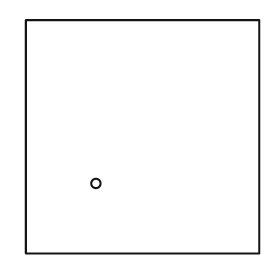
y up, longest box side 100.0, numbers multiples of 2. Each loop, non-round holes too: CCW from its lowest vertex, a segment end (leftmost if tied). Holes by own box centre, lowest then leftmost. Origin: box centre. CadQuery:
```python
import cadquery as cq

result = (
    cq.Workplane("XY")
    .moveTo(-50.0, -50.0)
    .lineTo(50.0, -50.0)
    .lineTo(50.0, 50.0)
    .lineTo(-50.0, 50.0)
    .close()
    .moveTo(-20.0, -20.0)
    .circle(2.0)
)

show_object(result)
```